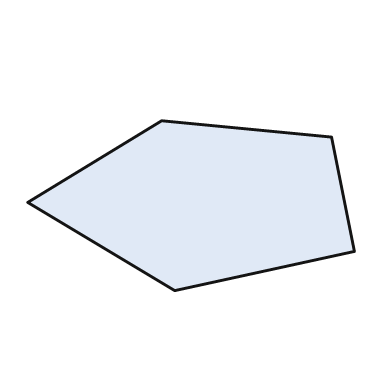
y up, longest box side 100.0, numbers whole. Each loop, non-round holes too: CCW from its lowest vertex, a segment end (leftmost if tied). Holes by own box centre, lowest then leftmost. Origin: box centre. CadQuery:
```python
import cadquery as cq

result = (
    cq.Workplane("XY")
    .moveTo(-5.0, -26.0)
    .lineTo(50.0, -14.0)
    .lineTo(43.0, 21.0)
    .lineTo(-9.0, 26.0)
    .lineTo(-50.0, 1.0)
    .close()
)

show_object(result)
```